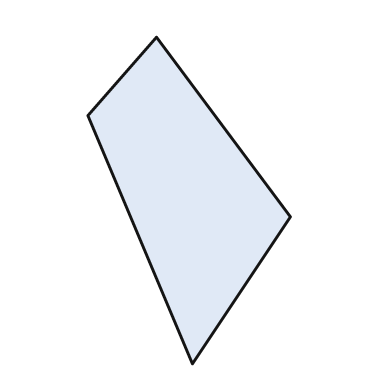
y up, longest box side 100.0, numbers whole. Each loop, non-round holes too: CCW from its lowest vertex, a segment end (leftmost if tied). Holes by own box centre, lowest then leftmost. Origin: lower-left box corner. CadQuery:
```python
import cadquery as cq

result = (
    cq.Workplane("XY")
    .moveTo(32.0, 0.0)
    .lineTo(62.0, 45.0)
    .lineTo(21.0, 100.0)
    .lineTo(0.0, 76.0)
    .close()
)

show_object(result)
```